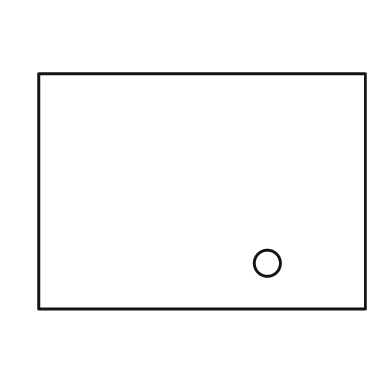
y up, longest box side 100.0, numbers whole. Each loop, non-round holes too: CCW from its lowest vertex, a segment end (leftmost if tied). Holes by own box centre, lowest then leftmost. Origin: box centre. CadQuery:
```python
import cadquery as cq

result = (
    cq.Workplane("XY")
    .moveTo(-50.0, -36.0)
    .lineTo(50.0, -36.0)
    .lineTo(50.0, 36.0)
    .lineTo(-50.0, 36.0)
    .close()
    .moveTo(20.0, -22.0)
    .circle(4.0)
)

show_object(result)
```